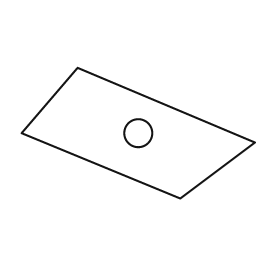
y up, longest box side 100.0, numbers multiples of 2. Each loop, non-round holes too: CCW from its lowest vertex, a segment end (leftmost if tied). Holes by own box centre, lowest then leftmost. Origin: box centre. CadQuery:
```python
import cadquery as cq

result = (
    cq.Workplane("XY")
    .moveTo(18.0, -28.0)
    .lineTo(50.0, -4.0)
    .lineTo(-26.0, 28.0)
    .lineTo(-50.0, 0.0)
    .close()
    .moveTo(0.0, 0.0)
    .circle(6.0)
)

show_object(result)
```